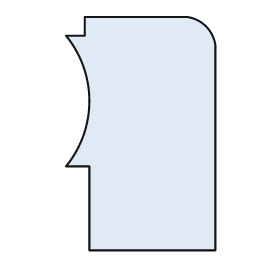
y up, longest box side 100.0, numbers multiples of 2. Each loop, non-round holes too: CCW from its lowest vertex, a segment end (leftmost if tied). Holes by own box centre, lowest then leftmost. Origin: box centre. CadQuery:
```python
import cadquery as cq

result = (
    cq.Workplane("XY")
    .moveTo(-22.0, -50.0)
    .lineTo(32.0, -50.0)
    .lineTo(32.0, 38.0)
    .threePointArc((28.0, 46.0), (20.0, 50.0))
    .lineTo(-24.0, 50.0)
    .lineTo(-24.0, 42.0)
    .lineTo(-32.0, 42.0)
    .threePointArc((-22.0, 14.0), (-32.0, -14.0))
    .lineTo(-22.0, -14.0)
    .close()
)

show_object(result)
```